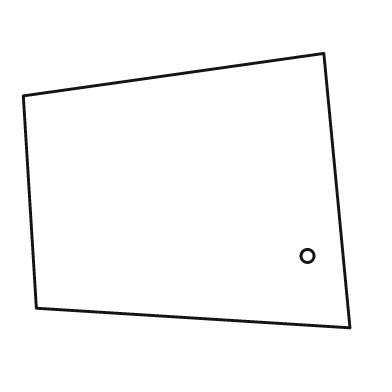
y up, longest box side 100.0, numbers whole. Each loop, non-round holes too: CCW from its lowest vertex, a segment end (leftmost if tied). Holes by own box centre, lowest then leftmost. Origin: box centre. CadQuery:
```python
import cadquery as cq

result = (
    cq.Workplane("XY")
    .moveTo(50.0, -42.0)
    .lineTo(42.0, 42.0)
    .lineTo(-50.0, 29.0)
    .lineTo(-46.0, -36.0)
    .close()
    .moveTo(37.0, -20.0)
    .circle(2.0)
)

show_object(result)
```